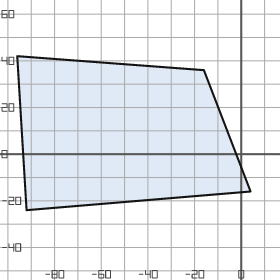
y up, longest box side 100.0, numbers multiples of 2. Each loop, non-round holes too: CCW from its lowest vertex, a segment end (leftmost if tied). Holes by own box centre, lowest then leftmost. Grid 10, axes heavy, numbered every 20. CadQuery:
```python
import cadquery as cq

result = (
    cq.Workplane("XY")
    .moveTo(-92.0, -24.0)
    .lineTo(4.0, -16.0)
    .lineTo(-16.0, 36.0)
    .lineTo(-96.0, 42.0)
    .close()
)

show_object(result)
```